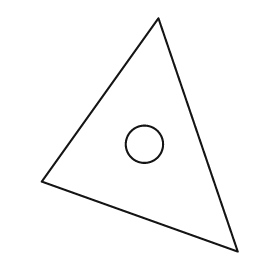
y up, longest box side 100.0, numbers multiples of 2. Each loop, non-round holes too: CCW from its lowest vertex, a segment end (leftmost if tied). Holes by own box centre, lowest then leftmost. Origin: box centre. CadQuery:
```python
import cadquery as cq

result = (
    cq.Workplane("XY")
    .moveTo(42.0, -50.0)
    .lineTo(8.0, 50.0)
    .lineTo(-42.0, -20.0)
    .close()
    .moveTo(2.0, -4.0)
    .circle(8.0)
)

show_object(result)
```